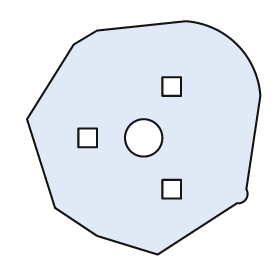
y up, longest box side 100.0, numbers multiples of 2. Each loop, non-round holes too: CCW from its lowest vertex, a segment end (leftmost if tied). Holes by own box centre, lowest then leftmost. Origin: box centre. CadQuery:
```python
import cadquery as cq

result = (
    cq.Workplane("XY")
    .moveTo(6.0, -50.0)
    .lineTo(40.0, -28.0)
    .threePointArc((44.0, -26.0), (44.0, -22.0))
    .lineTo(50.0, 18.0)
    .threePointArc((40.0, 40.0), (18.0, 50.0))
    .lineTo(-20.0, 46.0)
    .lineTo(-30.0, 40.0)
    .lineTo(-50.0, 8.0)
    .lineTo(-38.0, -30.0)
    .lineTo(-20.0, -42.0)
    .close()
    .moveTo(8.0, -26.0)
    .lineTo(16.0, -26.0)
    .lineTo(16.0, -18.0)
    .lineTo(8.0, -18.0)
    .close()
    .moveTo(-28.0, -4.0)
    .lineTo(-20.0, -4.0)
    .lineTo(-20.0, 4.0)
    .lineTo(-28.0, 4.0)
    .close()
    .moveTo(0.0, 0.0)
    .circle(8.0)
    .moveTo(8.0, 18.0)
    .lineTo(16.0, 18.0)
    .lineTo(16.0, 26.0)
    .lineTo(8.0, 26.0)
    .close()
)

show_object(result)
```